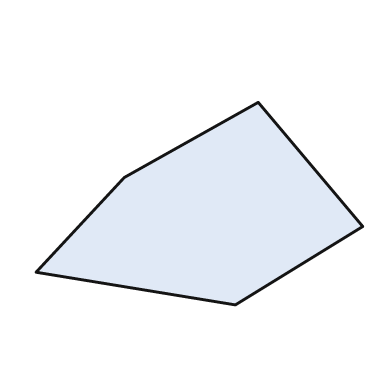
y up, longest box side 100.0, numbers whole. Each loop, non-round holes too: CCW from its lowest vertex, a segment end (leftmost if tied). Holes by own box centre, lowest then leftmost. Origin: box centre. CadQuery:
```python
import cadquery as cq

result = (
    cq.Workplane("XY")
    .moveTo(11.0, -31.0)
    .lineTo(50.0, -7.0)
    .lineTo(18.0, 31.0)
    .lineTo(-23.0, 8.0)
    .lineTo(-50.0, -21.0)
    .close()
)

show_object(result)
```